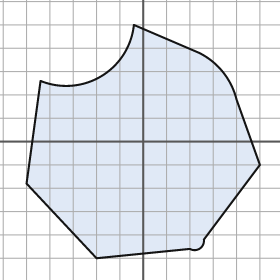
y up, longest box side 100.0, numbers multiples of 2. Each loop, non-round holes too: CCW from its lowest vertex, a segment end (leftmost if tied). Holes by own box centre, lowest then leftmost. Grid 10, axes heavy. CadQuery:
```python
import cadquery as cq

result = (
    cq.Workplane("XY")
    .moveTo(-20.0, -50.0)
    .lineTo(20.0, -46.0)
    .threePointArc((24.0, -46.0), (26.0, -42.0))
    .lineTo(50.0, -10.0)
    .lineTo(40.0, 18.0)
    .threePointArc((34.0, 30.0), (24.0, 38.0))
    .lineTo(-4.0, 50.0)
    .threePointArc((-18.0, 28.0), (-44.0, 26.0))
    .lineTo(-50.0, -18.0)
    .close()
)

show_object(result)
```